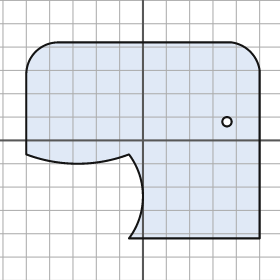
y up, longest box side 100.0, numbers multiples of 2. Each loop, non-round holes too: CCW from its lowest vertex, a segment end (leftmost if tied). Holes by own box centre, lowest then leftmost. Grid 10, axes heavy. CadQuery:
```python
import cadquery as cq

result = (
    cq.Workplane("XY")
    .moveTo(-6.0, -42.0)
    .lineTo(50.0, -42.0)
    .lineTo(50.0, 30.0)
    .threePointArc((46.0, 38.0), (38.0, 42.0))
    .lineTo(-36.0, 42.0)
    .threePointArc((-46.0, 38.0), (-50.0, 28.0))
    .lineTo(-50.0, -6.0)
    .threePointArc((-28.0, -10.0), (-6.0, -6.0))
    .threePointArc((0.0, -24.0), (-6.0, -42.0))
    .close()
    .moveTo(36.0, 8.0)
    .circle(2.0)
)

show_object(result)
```